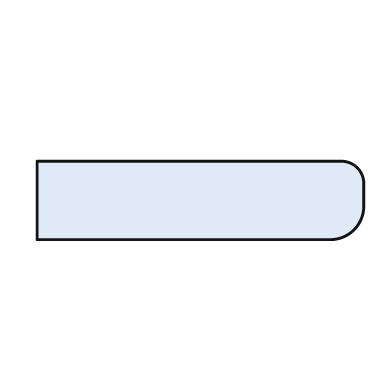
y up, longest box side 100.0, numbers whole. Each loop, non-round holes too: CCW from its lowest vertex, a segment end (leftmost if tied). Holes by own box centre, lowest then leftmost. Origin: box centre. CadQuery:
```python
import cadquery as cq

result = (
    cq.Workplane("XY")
    .moveTo(-50.0, -12.0)
    .lineTo(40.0, -12.0)
    .threePointArc((47.0, -9.0), (50.0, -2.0))
    .lineTo(50.0, 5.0)
    .threePointArc((48.0, 10.0), (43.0, 12.0))
    .lineTo(-50.0, 12.0)
    .close()
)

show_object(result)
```